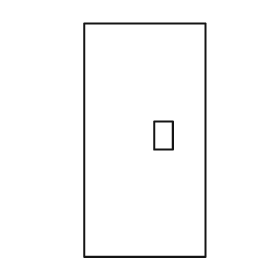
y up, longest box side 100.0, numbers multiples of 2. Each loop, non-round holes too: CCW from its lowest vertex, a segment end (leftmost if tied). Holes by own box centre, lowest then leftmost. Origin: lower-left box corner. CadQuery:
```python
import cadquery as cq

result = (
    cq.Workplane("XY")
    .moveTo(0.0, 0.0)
    .lineTo(52.0, 0.0)
    .lineTo(52.0, 100.0)
    .lineTo(0.0, 100.0)
    .close()
    .moveTo(30.0, 46.0)
    .lineTo(38.0, 46.0)
    .lineTo(38.0, 58.0)
    .lineTo(30.0, 58.0)
    .close()
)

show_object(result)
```